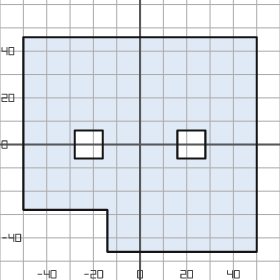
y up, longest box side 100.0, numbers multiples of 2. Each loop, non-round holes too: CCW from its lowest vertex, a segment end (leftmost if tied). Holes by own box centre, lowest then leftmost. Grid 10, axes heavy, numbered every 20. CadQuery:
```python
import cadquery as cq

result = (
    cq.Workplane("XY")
    .moveTo(-14.0, -46.0)
    .lineTo(50.0, -46.0)
    .lineTo(50.0, 46.0)
    .lineTo(-50.0, 46.0)
    .lineTo(-50.0, -28.0)
    .lineTo(-14.0, -28.0)
    .close()
    .moveTo(-28.0, -6.0)
    .lineTo(-16.0, -6.0)
    .lineTo(-16.0, 6.0)
    .lineTo(-28.0, 6.0)
    .close()
    .moveTo(16.0, -6.0)
    .lineTo(28.0, -6.0)
    .lineTo(28.0, 6.0)
    .lineTo(16.0, 6.0)
    .close()
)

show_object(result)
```